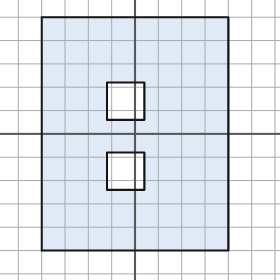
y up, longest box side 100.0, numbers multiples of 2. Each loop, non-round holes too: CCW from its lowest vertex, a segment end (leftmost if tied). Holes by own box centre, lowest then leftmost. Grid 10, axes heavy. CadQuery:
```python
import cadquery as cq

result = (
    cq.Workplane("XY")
    .moveTo(-40.0, -50.0)
    .lineTo(40.0, -50.0)
    .lineTo(40.0, 50.0)
    .lineTo(-40.0, 50.0)
    .close()
    .moveTo(-12.0, -24.0)
    .lineTo(4.0, -24.0)
    .lineTo(4.0, -8.0)
    .lineTo(-12.0, -8.0)
    .close()
    .moveTo(-12.0, 6.0)
    .lineTo(4.0, 6.0)
    .lineTo(4.0, 22.0)
    .lineTo(-12.0, 22.0)
    .close()
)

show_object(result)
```